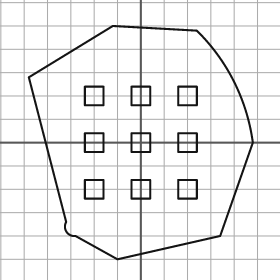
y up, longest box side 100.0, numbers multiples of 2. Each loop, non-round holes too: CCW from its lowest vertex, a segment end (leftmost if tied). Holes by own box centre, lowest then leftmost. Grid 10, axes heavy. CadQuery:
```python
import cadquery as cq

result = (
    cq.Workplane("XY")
    .moveTo(-10.0, -50.0)
    .lineTo(34.0, -40.0)
    .lineTo(48.0, 0.0)
    .threePointArc((40.0, 26.0), (24.0, 48.0))
    .lineTo(-12.0, 50.0)
    .lineTo(-48.0, 28.0)
    .lineTo(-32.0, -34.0)
    .threePointArc((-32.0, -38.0), (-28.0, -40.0))
    .close()
    .moveTo(-24.0, -24.0)
    .lineTo(-16.0, -24.0)
    .lineTo(-16.0, -16.0)
    .lineTo(-24.0, -16.0)
    .close()
    .moveTo(-4.0, -24.0)
    .lineTo(4.0, -24.0)
    .lineTo(4.0, -16.0)
    .lineTo(-4.0, -16.0)
    .close()
    .moveTo(16.0, -24.0)
    .lineTo(24.0, -24.0)
    .lineTo(24.0, -16.0)
    .lineTo(16.0, -16.0)
    .close()
    .moveTo(-24.0, -4.0)
    .lineTo(-16.0, -4.0)
    .lineTo(-16.0, 4.0)
    .lineTo(-24.0, 4.0)
    .close()
    .moveTo(-4.0, -4.0)
    .lineTo(4.0, -4.0)
    .lineTo(4.0, 4.0)
    .lineTo(-4.0, 4.0)
    .close()
    .moveTo(16.0, -4.0)
    .lineTo(24.0, -4.0)
    .lineTo(24.0, 4.0)
    .lineTo(16.0, 4.0)
    .close()
    .moveTo(-24.0, 16.0)
    .lineTo(-16.0, 16.0)
    .lineTo(-16.0, 24.0)
    .lineTo(-24.0, 24.0)
    .close()
    .moveTo(-4.0, 16.0)
    .lineTo(4.0, 16.0)
    .lineTo(4.0, 24.0)
    .lineTo(-4.0, 24.0)
    .close()
    .moveTo(16.0, 16.0)
    .lineTo(24.0, 16.0)
    .lineTo(24.0, 24.0)
    .lineTo(16.0, 24.0)
    .close()
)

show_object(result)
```